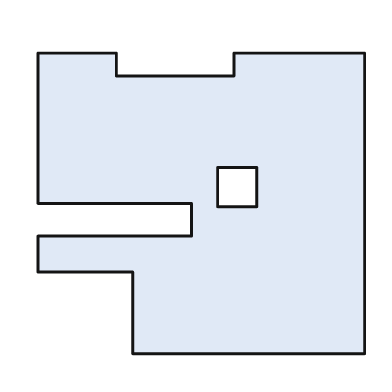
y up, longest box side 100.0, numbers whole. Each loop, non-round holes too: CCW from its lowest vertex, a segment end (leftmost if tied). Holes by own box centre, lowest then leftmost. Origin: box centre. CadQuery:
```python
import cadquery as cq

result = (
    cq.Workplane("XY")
    .moveTo(-21.0, -46.0)
    .lineTo(50.0, -46.0)
    .lineTo(50.0, 46.0)
    .lineTo(10.0, 46.0)
    .lineTo(10.0, 39.0)
    .lineTo(-26.0, 39.0)
    .lineTo(-26.0, 46.0)
    .lineTo(-50.0, 46.0)
    .lineTo(-50.0, 0.0)
    .lineTo(-3.0, 0.0)
    .lineTo(-3.0, -10.0)
    .lineTo(-50.0, -10.0)
    .lineTo(-50.0, -21.0)
    .lineTo(-21.0, -21.0)
    .close()
    .moveTo(5.0, -1.0)
    .lineTo(17.0, -1.0)
    .lineTo(17.0, 11.0)
    .lineTo(5.0, 11.0)
    .close()
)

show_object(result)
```